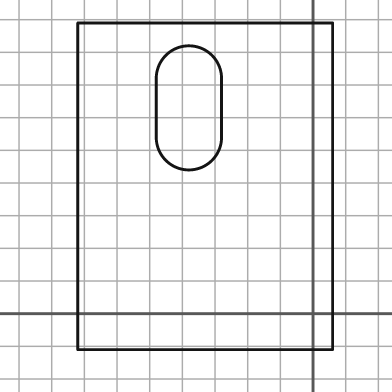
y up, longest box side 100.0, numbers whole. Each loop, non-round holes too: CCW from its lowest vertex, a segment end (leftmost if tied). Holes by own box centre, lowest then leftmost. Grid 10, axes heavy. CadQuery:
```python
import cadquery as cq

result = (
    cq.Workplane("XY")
    .moveTo(-72.0, -11.0)
    .lineTo(6.0, -11.0)
    .lineTo(6.0, 89.0)
    .lineTo(-72.0, 89.0)
    .close()
    .moveTo(-48.0, 54.0)
    .threePointArc((-38.0, 44.0), (-28.0, 54.0))
    .lineTo(-28.0, 72.0)
    .threePointArc((-38.0, 82.0), (-48.0, 72.0))
    .close()
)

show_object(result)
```